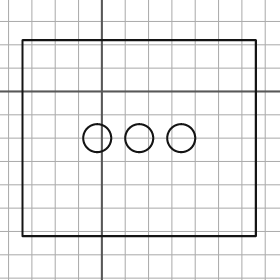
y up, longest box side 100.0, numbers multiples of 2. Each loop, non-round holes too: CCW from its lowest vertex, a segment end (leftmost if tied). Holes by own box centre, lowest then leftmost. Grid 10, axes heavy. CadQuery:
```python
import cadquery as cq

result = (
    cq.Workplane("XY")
    .moveTo(-34.0, -62.0)
    .lineTo(66.0, -62.0)
    .lineTo(66.0, 22.0)
    .lineTo(-34.0, 22.0)
    .close()
    .moveTo(-2.0, -20.0)
    .circle(6.0)
    .moveTo(16.0, -20.0)
    .circle(6.0)
    .moveTo(34.0, -20.0)
    .circle(6.0)
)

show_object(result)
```